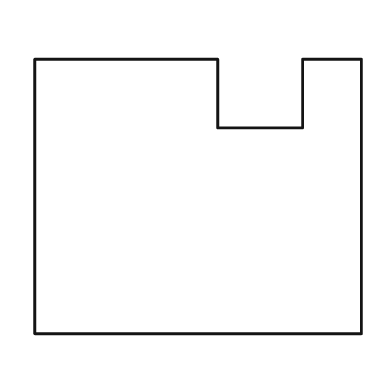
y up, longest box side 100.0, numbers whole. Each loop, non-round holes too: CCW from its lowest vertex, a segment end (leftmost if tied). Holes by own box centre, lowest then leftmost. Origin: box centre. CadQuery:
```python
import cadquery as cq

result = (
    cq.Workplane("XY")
    .moveTo(-50.0, -42.0)
    .lineTo(50.0, -42.0)
    .lineTo(50.0, 42.0)
    .lineTo(32.0, 42.0)
    .lineTo(32.0, 21.0)
    .lineTo(6.0, 21.0)
    .lineTo(6.0, 42.0)
    .lineTo(-50.0, 42.0)
    .close()
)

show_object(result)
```